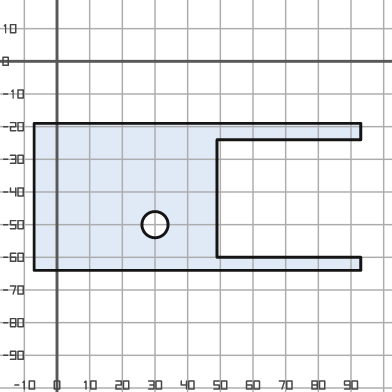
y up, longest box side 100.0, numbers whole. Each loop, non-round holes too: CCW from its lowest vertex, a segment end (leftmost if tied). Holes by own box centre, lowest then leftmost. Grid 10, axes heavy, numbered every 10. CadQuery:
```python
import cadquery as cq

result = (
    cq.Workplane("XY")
    .moveTo(-7.0, -64.0)
    .lineTo(93.0, -64.0)
    .lineTo(93.0, -60.0)
    .lineTo(49.0, -60.0)
    .lineTo(49.0, -24.0)
    .lineTo(93.0, -24.0)
    .lineTo(93.0, -19.0)
    .lineTo(-7.0, -19.0)
    .close()
    .moveTo(30.0, -50.0)
    .circle(4.0)
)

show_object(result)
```